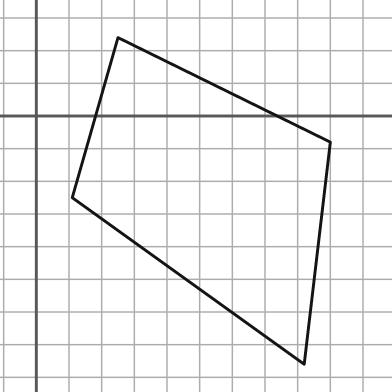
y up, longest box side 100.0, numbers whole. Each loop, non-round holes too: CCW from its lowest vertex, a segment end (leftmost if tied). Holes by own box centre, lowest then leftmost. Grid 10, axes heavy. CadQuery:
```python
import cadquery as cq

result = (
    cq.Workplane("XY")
    .moveTo(82.0, -76.0)
    .lineTo(90.0, -8.0)
    .lineTo(25.0, 24.0)
    .lineTo(11.0, -25.0)
    .close()
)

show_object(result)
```